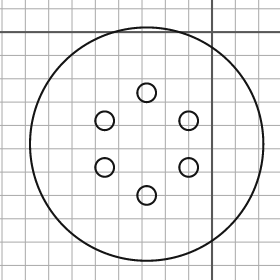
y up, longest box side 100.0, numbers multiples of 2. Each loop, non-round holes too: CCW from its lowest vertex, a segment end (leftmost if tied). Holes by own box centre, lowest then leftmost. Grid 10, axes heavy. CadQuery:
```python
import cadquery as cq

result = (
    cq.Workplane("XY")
    .moveTo(-28.0, -48.0)
    .circle(50.0)
    .moveTo(-28.0, -70.0)
    .circle(4.0)
    .moveTo(-46.0, -58.0)
    .circle(4.0)
    .moveTo(-10.0, -58.0)
    .circle(4.0)
    .moveTo(-46.0, -38.0)
    .circle(4.0)
    .moveTo(-10.0, -38.0)
    .circle(4.0)
    .moveTo(-28.0, -26.0)
    .circle(4.0)
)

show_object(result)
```